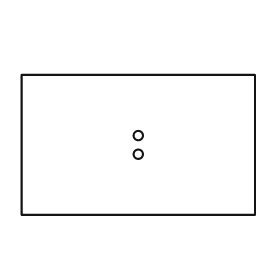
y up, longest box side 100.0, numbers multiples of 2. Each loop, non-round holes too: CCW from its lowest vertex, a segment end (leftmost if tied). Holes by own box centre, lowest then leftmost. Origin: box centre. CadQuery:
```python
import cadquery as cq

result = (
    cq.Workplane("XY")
    .moveTo(-50.0, -30.0)
    .lineTo(50.0, -30.0)
    .lineTo(50.0, 30.0)
    .lineTo(-50.0, 30.0)
    .close()
    .moveTo(0.0, -4.0)
    .circle(2.0)
    .moveTo(0.0, 4.0)
    .circle(2.0)
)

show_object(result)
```